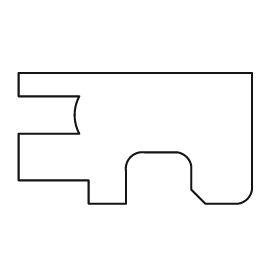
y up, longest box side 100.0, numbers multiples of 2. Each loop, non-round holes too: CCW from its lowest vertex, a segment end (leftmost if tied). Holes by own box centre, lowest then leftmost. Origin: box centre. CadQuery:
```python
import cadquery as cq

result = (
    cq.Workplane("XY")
    .moveTo(-20.0, -28.0)
    .lineTo(-4.0, -28.0)
    .lineTo(-4.0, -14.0)
    .threePointArc((-2.0, -8.0), (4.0, -6.0))
    .lineTo(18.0, -6.0)
    .threePointArc((22.0, -8.0), (24.0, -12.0))
    .lineTo(24.0, -22.0)
    .lineTo(30.0, -28.0)
    .lineTo(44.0, -28.0)
    .threePointArc((48.0, -26.0), (50.0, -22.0))
    .lineTo(50.0, 28.0)
    .lineTo(-50.0, 28.0)
    .lineTo(-50.0, 18.0)
    .lineTo(-24.0, 18.0)
    .threePointArc((-26.0, 10.0), (-24.0, 2.0))
    .lineTo(-50.0, 2.0)
    .lineTo(-50.0, -18.0)
    .lineTo(-20.0, -18.0)
    .close()
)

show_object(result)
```